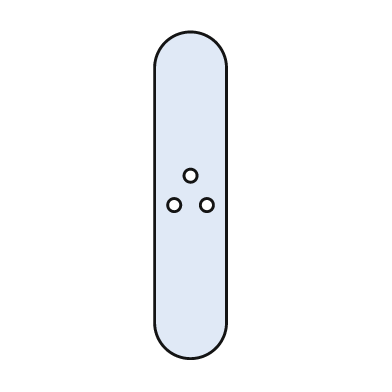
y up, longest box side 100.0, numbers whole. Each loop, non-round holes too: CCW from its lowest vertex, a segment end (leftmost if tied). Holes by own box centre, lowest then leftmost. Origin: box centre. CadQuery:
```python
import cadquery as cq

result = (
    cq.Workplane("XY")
    .moveTo(-11.0, -39.0)
    .threePointArc((0.0, -50.0), (11.0, -39.0))
    .lineTo(11.0, 39.0)
    .threePointArc((0.0, 50.0), (-11.0, 39.0))
    .close()
    .moveTo(-5.0, -3.0)
    .circle(2.0)
    .moveTo(5.0, -3.0)
    .circle(2.0)
    .moveTo(0.0, 6.0)
    .circle(2.0)
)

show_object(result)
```